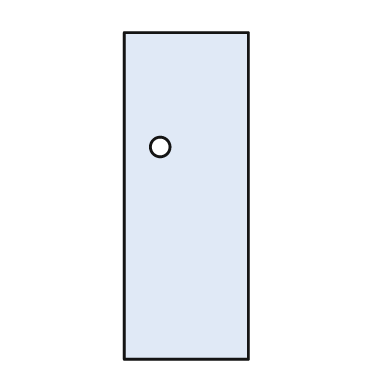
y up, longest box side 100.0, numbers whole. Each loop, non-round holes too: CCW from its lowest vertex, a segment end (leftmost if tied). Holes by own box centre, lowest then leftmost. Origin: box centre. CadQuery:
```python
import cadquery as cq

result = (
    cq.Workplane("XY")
    .moveTo(-19.0, -50.0)
    .lineTo(19.0, -50.0)
    .lineTo(19.0, 50.0)
    .lineTo(-19.0, 50.0)
    .close()
    .moveTo(-8.0, 15.0)
    .circle(3.0)
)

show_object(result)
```